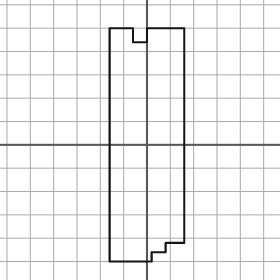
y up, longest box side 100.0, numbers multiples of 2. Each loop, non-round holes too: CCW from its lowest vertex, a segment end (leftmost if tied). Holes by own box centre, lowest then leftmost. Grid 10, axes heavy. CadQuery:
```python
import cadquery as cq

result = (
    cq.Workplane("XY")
    .moveTo(-16.0, -50.0)
    .lineTo(2.0, -50.0)
    .lineTo(2.0, -46.0)
    .lineTo(8.0, -46.0)
    .lineTo(8.0, -42.0)
    .lineTo(16.0, -42.0)
    .lineTo(16.0, 50.0)
    .lineTo(0.0, 50.0)
    .lineTo(0.0, 44.0)
    .lineTo(-6.0, 44.0)
    .lineTo(-6.0, 50.0)
    .lineTo(-16.0, 50.0)
    .close()
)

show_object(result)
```